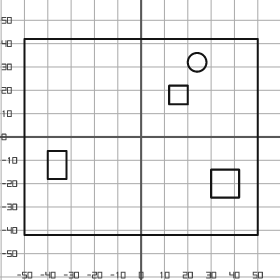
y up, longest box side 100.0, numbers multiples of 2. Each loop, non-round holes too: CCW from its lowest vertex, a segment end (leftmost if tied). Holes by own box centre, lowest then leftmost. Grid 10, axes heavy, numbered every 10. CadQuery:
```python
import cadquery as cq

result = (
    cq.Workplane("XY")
    .moveTo(-50.0, -42.0)
    .lineTo(50.0, -42.0)
    .lineTo(50.0, 42.0)
    .lineTo(-50.0, 42.0)
    .close()
    .moveTo(30.0, -26.0)
    .lineTo(42.0, -26.0)
    .lineTo(42.0, -14.0)
    .lineTo(30.0, -14.0)
    .close()
    .moveTo(-40.0, -18.0)
    .lineTo(-32.0, -18.0)
    .lineTo(-32.0, -6.0)
    .lineTo(-40.0, -6.0)
    .close()
    .moveTo(12.0, 14.0)
    .lineTo(20.0, 14.0)
    .lineTo(20.0, 22.0)
    .lineTo(12.0, 22.0)
    .close()
    .moveTo(24.0, 32.0)
    .circle(4.0)
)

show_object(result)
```